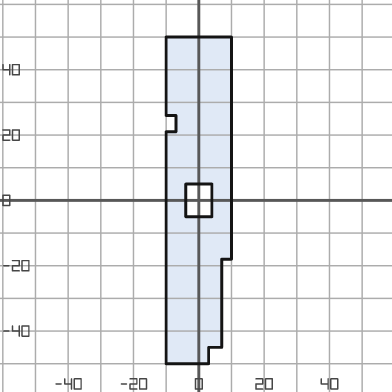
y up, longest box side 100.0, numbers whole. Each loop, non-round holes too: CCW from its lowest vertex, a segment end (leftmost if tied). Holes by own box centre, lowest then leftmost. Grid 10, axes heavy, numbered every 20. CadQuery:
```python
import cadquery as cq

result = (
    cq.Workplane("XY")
    .moveTo(-10.0, -50.0)
    .lineTo(3.0, -50.0)
    .lineTo(3.0, -45.0)
    .lineTo(7.0, -45.0)
    .lineTo(7.0, -18.0)
    .lineTo(10.0, -18.0)
    .lineTo(10.0, 50.0)
    .lineTo(-10.0, 50.0)
    .lineTo(-10.0, 26.0)
    .lineTo(-7.0, 26.0)
    .lineTo(-7.0, 21.0)
    .lineTo(-10.0, 21.0)
    .close()
    .moveTo(-4.0, -5.0)
    .lineTo(4.0, -5.0)
    .lineTo(4.0, 5.0)
    .lineTo(-4.0, 5.0)
    .close()
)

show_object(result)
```